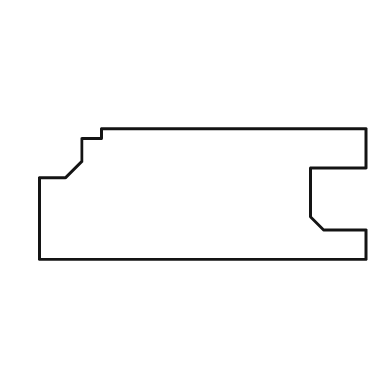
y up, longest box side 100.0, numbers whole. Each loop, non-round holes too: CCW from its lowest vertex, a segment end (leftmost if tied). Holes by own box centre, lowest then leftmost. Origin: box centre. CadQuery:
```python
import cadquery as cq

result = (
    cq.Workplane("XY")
    .moveTo(-50.0, -20.0)
    .lineTo(50.0, -20.0)
    .lineTo(50.0, -11.0)
    .lineTo(37.0, -11.0)
    .lineTo(33.0, -7.0)
    .lineTo(33.0, 8.0)
    .lineTo(50.0, 8.0)
    .lineTo(50.0, 20.0)
    .lineTo(-31.0, 20.0)
    .lineTo(-31.0, 17.0)
    .lineTo(-37.0, 17.0)
    .lineTo(-37.0, 10.0)
    .lineTo(-42.0, 5.0)
    .lineTo(-50.0, 5.0)
    .close()
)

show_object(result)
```